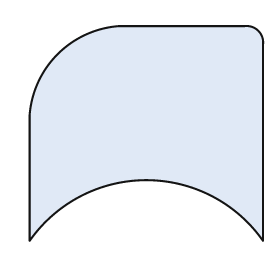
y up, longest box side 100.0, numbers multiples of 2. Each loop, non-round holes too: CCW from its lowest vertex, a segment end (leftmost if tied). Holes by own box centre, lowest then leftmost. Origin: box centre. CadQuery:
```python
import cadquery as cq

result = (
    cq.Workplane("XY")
    .moveTo(-50.0, -46.0)
    .threePointArc((0.0, -20.0), (50.0, -46.0))
    .lineTo(50.0, 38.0)
    .threePointArc((48.0, 44.0), (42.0, 46.0))
    .lineTo(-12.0, 46.0)
    .threePointArc((-38.0, 34.0), (-50.0, 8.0))
    .close()
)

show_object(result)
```